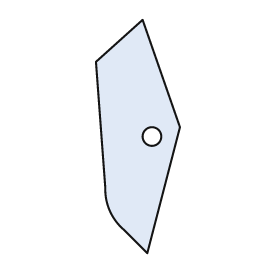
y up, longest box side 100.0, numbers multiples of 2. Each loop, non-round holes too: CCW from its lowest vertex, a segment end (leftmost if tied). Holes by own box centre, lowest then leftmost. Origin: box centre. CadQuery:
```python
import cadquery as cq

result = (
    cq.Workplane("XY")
    .moveTo(4.0, -50.0)
    .lineTo(18.0, 4.0)
    .lineTo(2.0, 50.0)
    .lineTo(-18.0, 32.0)
    .lineTo(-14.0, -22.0)
    .threePointArc((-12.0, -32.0), (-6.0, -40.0))
    .close()
    .moveTo(6.0, 0.0)
    .circle(4.0)
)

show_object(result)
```